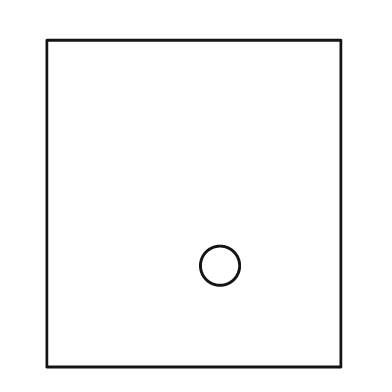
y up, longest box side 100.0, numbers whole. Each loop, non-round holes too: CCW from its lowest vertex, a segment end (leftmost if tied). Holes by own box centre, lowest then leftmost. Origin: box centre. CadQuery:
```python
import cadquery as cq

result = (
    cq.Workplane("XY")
    .moveTo(-45.0, -50.0)
    .lineTo(45.0, -50.0)
    .lineTo(45.0, 50.0)
    .lineTo(-45.0, 50.0)
    .close()
    .moveTo(8.0, -19.0)
    .circle(6.0)
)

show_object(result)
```